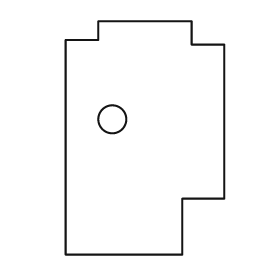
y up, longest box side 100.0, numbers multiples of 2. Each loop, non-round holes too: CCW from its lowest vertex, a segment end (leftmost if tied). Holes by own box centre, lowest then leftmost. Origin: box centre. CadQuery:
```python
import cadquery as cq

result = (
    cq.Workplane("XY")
    .moveTo(-34.0, -50.0)
    .lineTo(16.0, -50.0)
    .lineTo(16.0, -26.0)
    .lineTo(34.0, -26.0)
    .lineTo(34.0, 40.0)
    .lineTo(20.0, 40.0)
    .lineTo(20.0, 50.0)
    .lineTo(-20.0, 50.0)
    .lineTo(-20.0, 42.0)
    .lineTo(-34.0, 42.0)
    .close()
    .moveTo(-14.0, 8.0)
    .circle(6.0)
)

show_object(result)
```